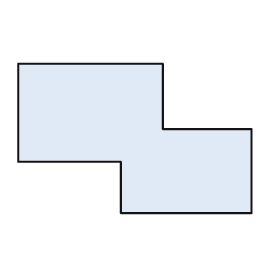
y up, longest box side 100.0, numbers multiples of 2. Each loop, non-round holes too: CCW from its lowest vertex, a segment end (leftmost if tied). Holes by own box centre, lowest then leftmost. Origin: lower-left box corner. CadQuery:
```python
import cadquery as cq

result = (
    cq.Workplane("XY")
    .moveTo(44.0, 0.0)
    .lineTo(100.0, 0.0)
    .lineTo(100.0, 36.0)
    .lineTo(62.0, 36.0)
    .lineTo(62.0, 64.0)
    .lineTo(0.0, 64.0)
    .lineTo(0.0, 22.0)
    .lineTo(44.0, 22.0)
    .close()
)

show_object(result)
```